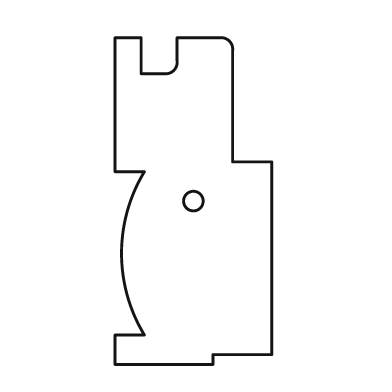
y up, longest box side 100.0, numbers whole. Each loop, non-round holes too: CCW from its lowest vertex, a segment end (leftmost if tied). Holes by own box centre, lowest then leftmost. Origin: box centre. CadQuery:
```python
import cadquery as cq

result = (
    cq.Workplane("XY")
    .moveTo(-24.0, -50.0)
    .lineTo(6.0, -50.0)
    .lineTo(6.0, -47.0)
    .lineTo(24.0, -47.0)
    .lineTo(24.0, 12.0)
    .lineTo(12.0, 12.0)
    .lineTo(12.0, 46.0)
    .threePointArc((11.0, 49.0), (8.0, 50.0))
    .lineTo(-5.0, 50.0)
    .lineTo(-5.0, 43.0)
    .threePointArc((-6.0, 40.0), (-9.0, 39.0))
    .lineTo(-16.0, 39.0)
    .lineTo(-16.0, 50.0)
    .lineTo(-24.0, 50.0)
    .lineTo(-24.0, 9.0)
    .lineTo(-15.0, 9.0)
    .threePointArc((-22.0, -16.0), (-15.0, -41.0))
    .lineTo(-24.0, -41.0)
    .close()
    .moveTo(0.0, 0.0)
    .circle(3.0)
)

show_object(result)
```